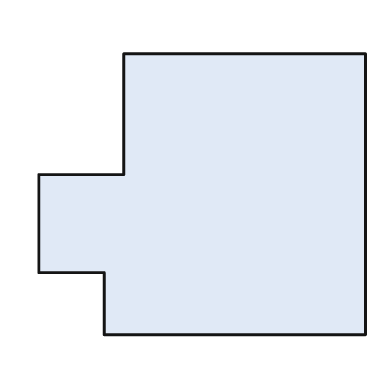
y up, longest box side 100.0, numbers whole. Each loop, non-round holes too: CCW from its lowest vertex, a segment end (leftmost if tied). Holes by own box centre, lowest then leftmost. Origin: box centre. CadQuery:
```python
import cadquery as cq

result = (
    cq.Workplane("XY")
    .moveTo(-30.0, -43.0)
    .lineTo(50.0, -43.0)
    .lineTo(50.0, 43.0)
    .lineTo(-24.0, 43.0)
    .lineTo(-24.0, 6.0)
    .lineTo(-50.0, 6.0)
    .lineTo(-50.0, -24.0)
    .lineTo(-30.0, -24.0)
    .close()
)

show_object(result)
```